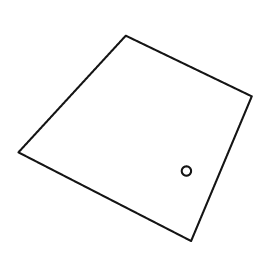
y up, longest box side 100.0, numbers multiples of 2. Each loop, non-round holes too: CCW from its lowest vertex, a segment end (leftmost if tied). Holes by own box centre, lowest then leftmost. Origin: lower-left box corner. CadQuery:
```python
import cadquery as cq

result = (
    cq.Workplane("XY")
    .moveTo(74.0, 0.0)
    .lineTo(100.0, 62.0)
    .lineTo(46.0, 88.0)
    .lineTo(0.0, 38.0)
    .close()
    .moveTo(72.0, 30.0)
    .circle(2.0)
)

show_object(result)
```